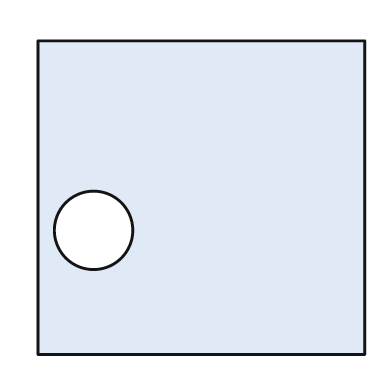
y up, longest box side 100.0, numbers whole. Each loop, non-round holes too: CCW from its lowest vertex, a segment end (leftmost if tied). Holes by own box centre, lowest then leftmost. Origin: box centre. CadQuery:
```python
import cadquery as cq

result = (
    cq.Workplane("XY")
    .moveTo(-50.0, -48.0)
    .lineTo(50.0, -48.0)
    .lineTo(50.0, 48.0)
    .lineTo(-50.0, 48.0)
    .close()
    .moveTo(-33.0, -10.0)
    .circle(12.0)
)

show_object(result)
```